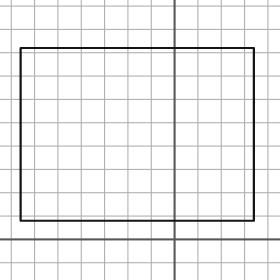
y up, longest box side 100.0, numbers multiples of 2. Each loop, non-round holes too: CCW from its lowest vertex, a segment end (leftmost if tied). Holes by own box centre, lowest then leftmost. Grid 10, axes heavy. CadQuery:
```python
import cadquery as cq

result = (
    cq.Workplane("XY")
    .moveTo(-66.0, 8.0)
    .lineTo(34.0, 8.0)
    .lineTo(34.0, 82.0)
    .lineTo(-66.0, 82.0)
    .close()
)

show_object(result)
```